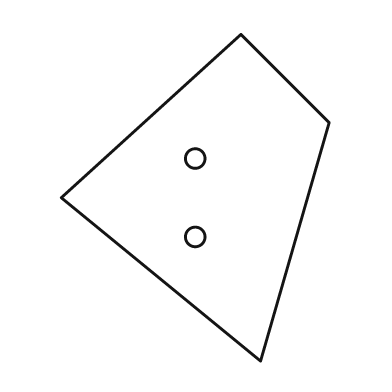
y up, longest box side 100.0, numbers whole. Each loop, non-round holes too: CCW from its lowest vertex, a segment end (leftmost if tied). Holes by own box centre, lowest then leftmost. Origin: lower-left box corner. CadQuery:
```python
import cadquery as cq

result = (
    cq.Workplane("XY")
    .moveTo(61.0, 0.0)
    .lineTo(82.0, 73.0)
    .lineTo(55.0, 100.0)
    .lineTo(0.0, 50.0)
    .close()
    .moveTo(41.0, 38.0)
    .circle(3.0)
    .moveTo(41.0, 62.0)
    .circle(3.0)
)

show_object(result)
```